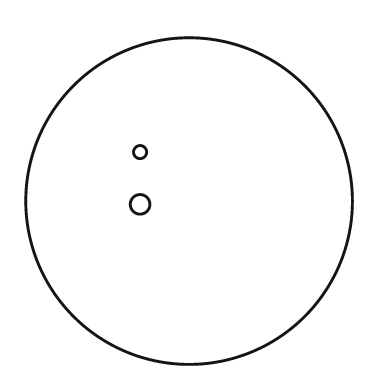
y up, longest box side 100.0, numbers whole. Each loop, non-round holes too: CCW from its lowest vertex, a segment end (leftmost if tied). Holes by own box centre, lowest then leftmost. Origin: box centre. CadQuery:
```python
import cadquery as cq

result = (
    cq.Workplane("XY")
    .moveTo(0.0, 0.0)
    .circle(50.0)
    .moveTo(-15.0, -1.0)
    .circle(3.0)
    .moveTo(-15.0, 15.0)
    .circle(2.0)
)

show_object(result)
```